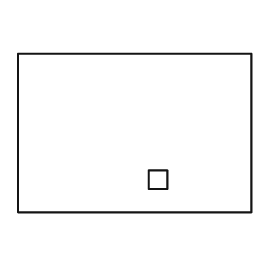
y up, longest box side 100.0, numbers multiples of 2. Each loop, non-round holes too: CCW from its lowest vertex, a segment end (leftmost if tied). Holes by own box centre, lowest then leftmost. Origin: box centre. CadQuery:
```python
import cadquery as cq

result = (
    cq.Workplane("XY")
    .moveTo(-50.0, -34.0)
    .lineTo(50.0, -34.0)
    .lineTo(50.0, 34.0)
    .lineTo(-50.0, 34.0)
    .close()
    .moveTo(6.0, -24.0)
    .lineTo(14.0, -24.0)
    .lineTo(14.0, -16.0)
    .lineTo(6.0, -16.0)
    .close()
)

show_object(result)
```